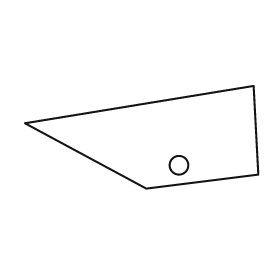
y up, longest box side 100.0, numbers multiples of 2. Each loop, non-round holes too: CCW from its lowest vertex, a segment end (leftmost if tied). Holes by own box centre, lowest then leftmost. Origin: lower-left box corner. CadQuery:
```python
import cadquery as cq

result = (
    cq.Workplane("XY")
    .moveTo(52.0, 0.0)
    .lineTo(100.0, 6.0)
    .lineTo(98.0, 44.0)
    .lineTo(0.0, 28.0)
    .close()
    .moveTo(66.0, 10.0)
    .circle(4.0)
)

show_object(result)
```